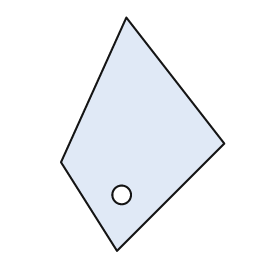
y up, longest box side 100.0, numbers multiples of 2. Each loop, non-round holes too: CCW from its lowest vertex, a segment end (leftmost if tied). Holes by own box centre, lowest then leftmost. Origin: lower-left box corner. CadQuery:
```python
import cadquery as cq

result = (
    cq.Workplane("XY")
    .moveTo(24.0, 0.0)
    .lineTo(70.0, 46.0)
    .lineTo(28.0, 100.0)
    .lineTo(0.0, 38.0)
    .close()
    .moveTo(26.0, 24.0)
    .circle(4.0)
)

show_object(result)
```